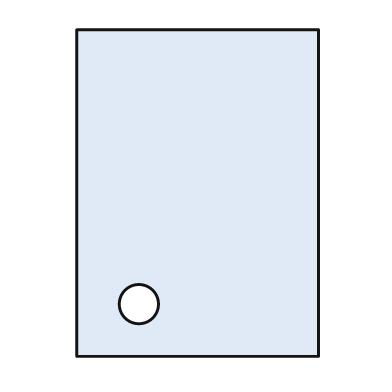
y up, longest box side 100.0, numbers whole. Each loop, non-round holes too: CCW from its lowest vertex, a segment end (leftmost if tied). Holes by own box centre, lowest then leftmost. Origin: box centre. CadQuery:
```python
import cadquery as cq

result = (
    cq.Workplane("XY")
    .moveTo(-37.0, -50.0)
    .lineTo(37.0, -50.0)
    .lineTo(37.0, 50.0)
    .lineTo(-37.0, 50.0)
    .close()
    .moveTo(-18.0, -34.0)
    .circle(6.0)
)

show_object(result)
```